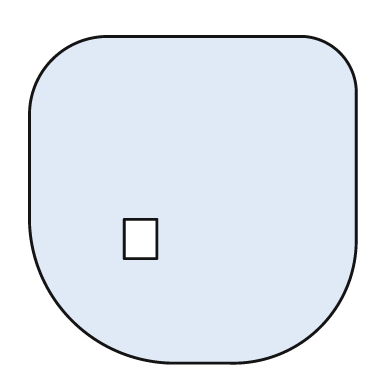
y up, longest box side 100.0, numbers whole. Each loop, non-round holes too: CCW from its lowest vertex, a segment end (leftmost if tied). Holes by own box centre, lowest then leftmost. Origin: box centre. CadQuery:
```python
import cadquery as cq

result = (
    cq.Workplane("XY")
    .moveTo(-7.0, -50.0)
    .lineTo(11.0, -50.0)
    .threePointArc((39.0, -39.0), (50.0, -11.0))
    .lineTo(50.0, 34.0)
    .threePointArc((45.0, 45.0), (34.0, 50.0))
    .lineTo(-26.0, 50.0)
    .threePointArc((-43.0, 43.0), (-50.0, 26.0))
    .lineTo(-50.0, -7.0)
    .threePointArc((-37.0, -37.0), (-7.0, -50.0))
    .close()
    .moveTo(-21.0, -18.0)
    .lineTo(-11.0, -18.0)
    .lineTo(-11.0, -6.0)
    .lineTo(-21.0, -6.0)
    .close()
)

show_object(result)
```